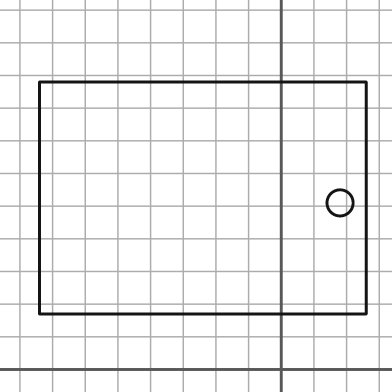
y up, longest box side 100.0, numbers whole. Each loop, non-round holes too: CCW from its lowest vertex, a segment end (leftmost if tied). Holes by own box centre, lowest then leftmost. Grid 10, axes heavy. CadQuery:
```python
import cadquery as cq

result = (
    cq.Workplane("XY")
    .moveTo(-74.0, 17.0)
    .lineTo(26.0, 17.0)
    .lineTo(26.0, 88.0)
    .lineTo(-74.0, 88.0)
    .close()
    .moveTo(18.0, 51.0)
    .circle(4.0)
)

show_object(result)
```